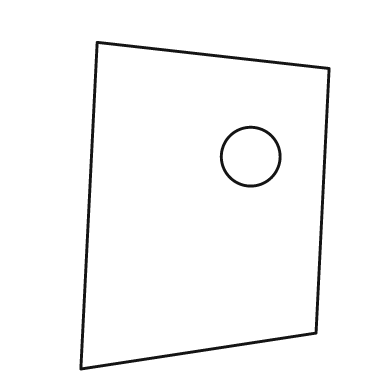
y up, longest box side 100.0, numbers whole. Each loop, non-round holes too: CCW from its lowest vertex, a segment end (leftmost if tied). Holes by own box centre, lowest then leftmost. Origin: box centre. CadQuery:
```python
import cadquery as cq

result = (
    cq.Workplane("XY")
    .moveTo(-38.0, -50.0)
    .lineTo(34.0, -39.0)
    .lineTo(38.0, 42.0)
    .lineTo(-33.0, 50.0)
    .close()
    .moveTo(14.0, 15.0)
    .circle(9.0)
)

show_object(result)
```